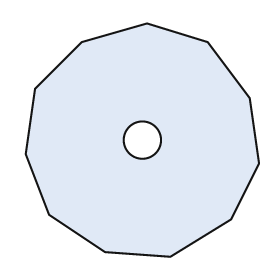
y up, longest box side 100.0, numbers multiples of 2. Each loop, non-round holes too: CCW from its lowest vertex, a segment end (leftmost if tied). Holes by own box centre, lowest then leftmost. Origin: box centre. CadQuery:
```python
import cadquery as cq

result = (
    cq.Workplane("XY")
    .moveTo(12.0, -50.0)
    .lineTo(38.0, -34.0)
    .lineTo(50.0, -10.0)
    .lineTo(46.0, 18.0)
    .lineTo(28.0, 42.0)
    .lineTo(2.0, 50.0)
    .lineTo(-26.0, 42.0)
    .lineTo(-46.0, 22.0)
    .lineTo(-50.0, -6.0)
    .lineTo(-40.0, -32.0)
    .lineTo(-16.0, -48.0)
    .close()
    .moveTo(0.0, 0.0)
    .circle(8.0)
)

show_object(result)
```